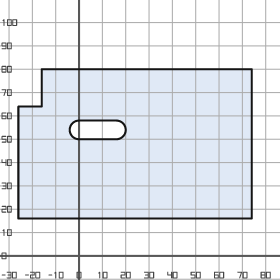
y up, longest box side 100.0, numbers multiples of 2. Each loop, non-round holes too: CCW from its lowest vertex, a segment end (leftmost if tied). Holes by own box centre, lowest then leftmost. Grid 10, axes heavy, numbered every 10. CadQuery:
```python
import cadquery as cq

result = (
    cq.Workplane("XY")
    .moveTo(-26.0, 16.0)
    .lineTo(74.0, 16.0)
    .lineTo(74.0, 80.0)
    .lineTo(-16.0, 80.0)
    .lineTo(-16.0, 64.0)
    .lineTo(-26.0, 64.0)
    .close()
    .moveTo(0.0, 50.0)
    .lineTo(16.0, 50.0)
    .threePointArc((20.0, 54.0), (16.0, 58.0))
    .lineTo(0.0, 58.0)
    .threePointArc((-4.0, 54.0), (0.0, 50.0))
    .close()
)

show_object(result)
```